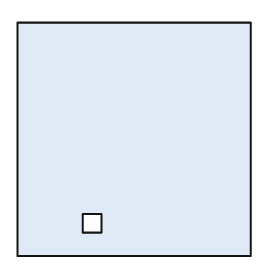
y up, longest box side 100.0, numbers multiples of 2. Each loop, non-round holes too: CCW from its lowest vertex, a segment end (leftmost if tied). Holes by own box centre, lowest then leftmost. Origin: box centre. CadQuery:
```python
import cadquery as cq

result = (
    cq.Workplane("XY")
    .moveTo(-50.0, -50.0)
    .lineTo(50.0, -50.0)
    .lineTo(50.0, 50.0)
    .lineTo(-50.0, 50.0)
    .close()
    .moveTo(-22.0, -40.0)
    .lineTo(-14.0, -40.0)
    .lineTo(-14.0, -32.0)
    .lineTo(-22.0, -32.0)
    .close()
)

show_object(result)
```